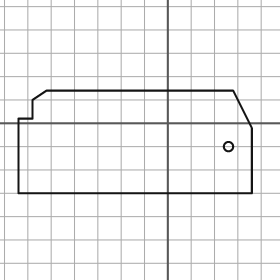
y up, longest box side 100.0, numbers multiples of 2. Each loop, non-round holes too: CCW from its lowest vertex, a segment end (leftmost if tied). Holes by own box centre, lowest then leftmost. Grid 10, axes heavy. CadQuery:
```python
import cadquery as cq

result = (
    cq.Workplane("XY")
    .moveTo(-64.0, -30.0)
    .lineTo(36.0, -30.0)
    .lineTo(36.0, -2.0)
    .lineTo(28.0, 14.0)
    .lineTo(-52.0, 14.0)
    .lineTo(-58.0, 10.0)
    .lineTo(-58.0, 2.0)
    .lineTo(-64.0, 2.0)
    .close()
    .moveTo(26.0, -10.0)
    .circle(2.0)
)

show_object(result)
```